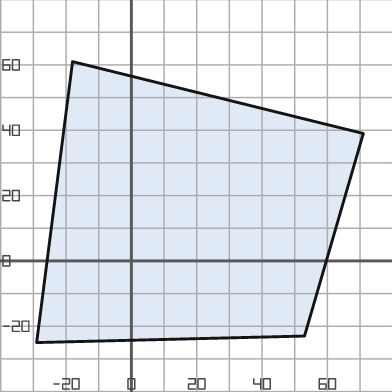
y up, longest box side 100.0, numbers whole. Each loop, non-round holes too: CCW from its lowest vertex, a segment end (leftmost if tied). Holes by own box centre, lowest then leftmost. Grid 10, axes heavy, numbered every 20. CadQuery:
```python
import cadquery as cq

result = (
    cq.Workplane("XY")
    .moveTo(-29.0, -25.0)
    .lineTo(53.0, -23.0)
    .lineTo(71.0, 39.0)
    .lineTo(-18.0, 61.0)
    .close()
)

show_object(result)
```